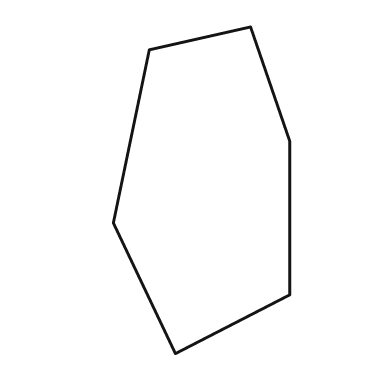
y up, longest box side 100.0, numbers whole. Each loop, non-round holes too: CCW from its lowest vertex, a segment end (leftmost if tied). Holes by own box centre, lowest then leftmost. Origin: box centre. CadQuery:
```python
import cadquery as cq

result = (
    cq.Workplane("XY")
    .moveTo(-8.0, -50.0)
    .lineTo(27.0, -32.0)
    .lineTo(27.0, 15.0)
    .lineTo(15.0, 50.0)
    .lineTo(-16.0, 43.0)
    .lineTo(-27.0, -10.0)
    .close()
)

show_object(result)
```